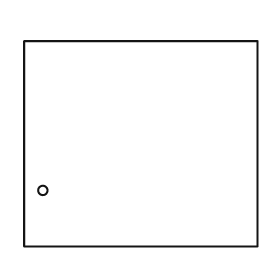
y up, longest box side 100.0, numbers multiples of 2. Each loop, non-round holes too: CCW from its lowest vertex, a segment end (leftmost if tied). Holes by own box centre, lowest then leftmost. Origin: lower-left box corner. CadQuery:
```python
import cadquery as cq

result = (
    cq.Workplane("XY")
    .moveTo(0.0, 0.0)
    .lineTo(100.0, 0.0)
    .lineTo(100.0, 88.0)
    .lineTo(0.0, 88.0)
    .close()
    .moveTo(8.0, 24.0)
    .circle(2.0)
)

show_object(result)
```